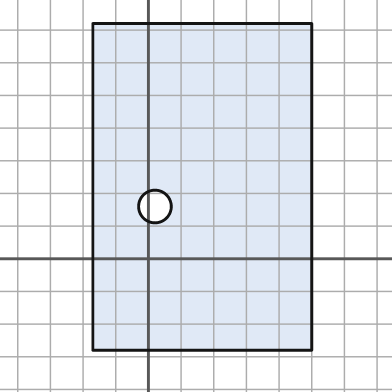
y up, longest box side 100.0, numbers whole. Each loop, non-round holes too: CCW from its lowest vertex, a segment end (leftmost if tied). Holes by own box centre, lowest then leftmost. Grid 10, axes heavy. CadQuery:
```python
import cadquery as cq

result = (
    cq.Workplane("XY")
    .moveTo(-17.0, -28.0)
    .lineTo(50.0, -28.0)
    .lineTo(50.0, 72.0)
    .lineTo(-17.0, 72.0)
    .close()
    .moveTo(2.0, 16.0)
    .circle(5.0)
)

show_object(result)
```